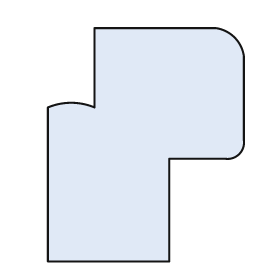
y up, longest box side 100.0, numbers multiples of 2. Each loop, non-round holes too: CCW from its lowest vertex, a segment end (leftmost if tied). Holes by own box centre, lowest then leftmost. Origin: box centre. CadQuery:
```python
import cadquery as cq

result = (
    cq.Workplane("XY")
    .moveTo(-42.0, -50.0)
    .lineTo(10.0, -50.0)
    .lineTo(10.0, -6.0)
    .lineTo(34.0, -6.0)
    .threePointArc((40.0, -4.0), (42.0, 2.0))
    .lineTo(42.0, 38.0)
    .threePointArc((38.0, 46.0), (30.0, 50.0))
    .lineTo(-22.0, 50.0)
    .lineTo(-22.0, 16.0)
    .threePointArc((-32.0, 18.0), (-42.0, 16.0))
    .close()
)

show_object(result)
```